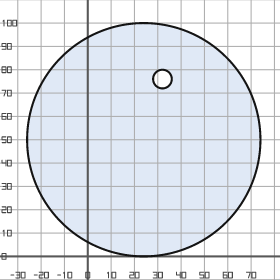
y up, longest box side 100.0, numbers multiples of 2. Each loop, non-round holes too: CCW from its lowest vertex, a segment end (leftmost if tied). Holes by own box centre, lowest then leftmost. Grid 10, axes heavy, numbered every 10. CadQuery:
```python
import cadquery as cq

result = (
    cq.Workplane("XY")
    .moveTo(24.0, 50.0)
    .circle(50.0)
    .moveTo(32.0, 76.0)
    .circle(4.0)
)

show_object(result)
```